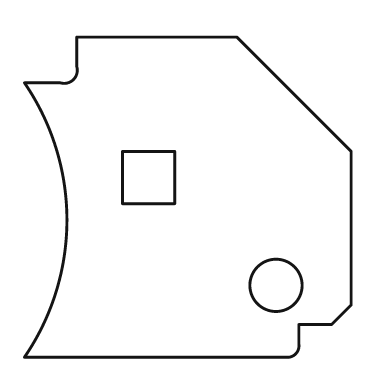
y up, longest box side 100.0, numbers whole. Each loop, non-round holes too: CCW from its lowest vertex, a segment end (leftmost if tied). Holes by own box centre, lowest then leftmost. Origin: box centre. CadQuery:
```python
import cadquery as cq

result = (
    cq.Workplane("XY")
    .moveTo(-50.0, -49.0)
    .lineTo(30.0, -49.0)
    .threePointArc((33.0, -48.0), (34.0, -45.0))
    .lineTo(34.0, -39.0)
    .lineTo(44.0, -39.0)
    .lineTo(50.0, -33.0)
    .lineTo(50.0, 14.0)
    .lineTo(15.0, 49.0)
    .lineTo(-34.0, 49.0)
    .lineTo(-34.0, 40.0)
    .threePointArc((-35.0, 36.0), (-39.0, 35.0))
    .lineTo(-50.0, 35.0)
    .threePointArc((-37.0, -7.0), (-50.0, -49.0))
    .close()
    .moveTo(27.0, -27.0)
    .circle(8.0)
    .moveTo(-20.0, -2.0)
    .lineTo(-4.0, -2.0)
    .lineTo(-4.0, 14.0)
    .lineTo(-20.0, 14.0)
    .close()
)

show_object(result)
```